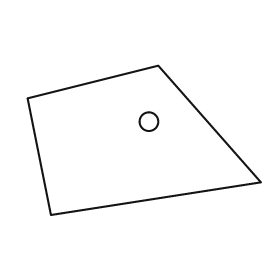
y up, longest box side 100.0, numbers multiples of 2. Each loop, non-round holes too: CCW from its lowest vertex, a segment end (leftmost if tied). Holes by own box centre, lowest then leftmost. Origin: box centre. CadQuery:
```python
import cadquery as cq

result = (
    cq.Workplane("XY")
    .moveTo(-40.0, -32.0)
    .lineTo(50.0, -18.0)
    .lineTo(6.0, 32.0)
    .lineTo(-50.0, 18.0)
    .close()
    .moveTo(2.0, 8.0)
    .circle(4.0)
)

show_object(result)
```